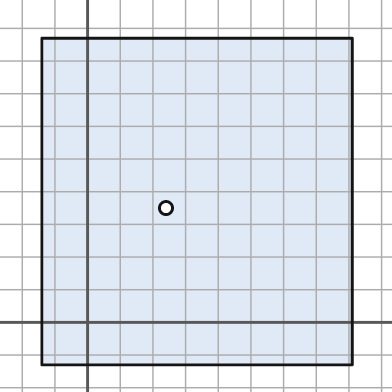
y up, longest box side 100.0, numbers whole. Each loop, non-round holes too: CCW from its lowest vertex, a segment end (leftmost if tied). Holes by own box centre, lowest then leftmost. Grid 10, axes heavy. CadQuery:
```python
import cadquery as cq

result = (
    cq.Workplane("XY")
    .moveTo(-14.0, -13.0)
    .lineTo(81.0, -13.0)
    .lineTo(81.0, 87.0)
    .lineTo(-14.0, 87.0)
    .close()
    .moveTo(24.0, 35.0)
    .circle(2.0)
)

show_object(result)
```